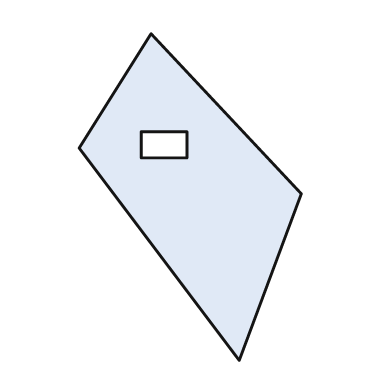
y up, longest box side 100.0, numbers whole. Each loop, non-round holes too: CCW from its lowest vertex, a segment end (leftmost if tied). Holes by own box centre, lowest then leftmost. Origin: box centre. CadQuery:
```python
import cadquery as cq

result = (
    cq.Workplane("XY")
    .moveTo(15.0, -50.0)
    .lineTo(34.0, 1.0)
    .lineTo(-12.0, 50.0)
    .lineTo(-34.0, 15.0)
    .close()
    .moveTo(-15.0, 12.0)
    .lineTo(-1.0, 12.0)
    .lineTo(-1.0, 20.0)
    .lineTo(-15.0, 20.0)
    .close()
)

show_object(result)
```